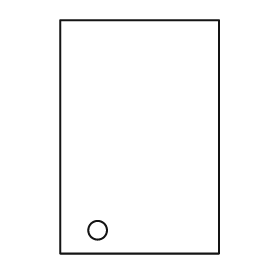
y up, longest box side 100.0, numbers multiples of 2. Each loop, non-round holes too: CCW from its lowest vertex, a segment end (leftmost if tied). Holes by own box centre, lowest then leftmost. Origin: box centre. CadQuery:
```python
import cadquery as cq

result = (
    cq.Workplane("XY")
    .moveTo(-34.0, -50.0)
    .lineTo(34.0, -50.0)
    .lineTo(34.0, 50.0)
    .lineTo(-34.0, 50.0)
    .close()
    .moveTo(-18.0, -40.0)
    .circle(4.0)
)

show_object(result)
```